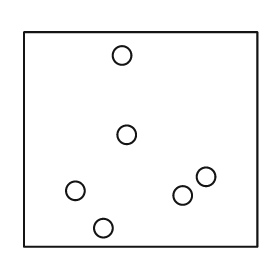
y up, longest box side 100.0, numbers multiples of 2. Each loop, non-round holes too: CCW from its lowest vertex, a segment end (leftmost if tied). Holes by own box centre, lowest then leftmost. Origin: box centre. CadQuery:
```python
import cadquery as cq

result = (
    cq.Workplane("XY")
    .moveTo(-50.0, -46.0)
    .lineTo(50.0, -46.0)
    .lineTo(50.0, 46.0)
    .lineTo(-50.0, 46.0)
    .close()
    .moveTo(-16.0, -38.0)
    .circle(4.0)
    .moveTo(18.0, -24.0)
    .circle(4.0)
    .moveTo(-28.0, -22.0)
    .circle(4.0)
    .moveTo(28.0, -16.0)
    .circle(4.0)
    .moveTo(-6.0, 2.0)
    .circle(4.0)
    .moveTo(-8.0, 36.0)
    .circle(4.0)
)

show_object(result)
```